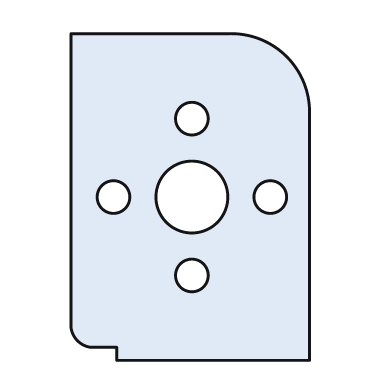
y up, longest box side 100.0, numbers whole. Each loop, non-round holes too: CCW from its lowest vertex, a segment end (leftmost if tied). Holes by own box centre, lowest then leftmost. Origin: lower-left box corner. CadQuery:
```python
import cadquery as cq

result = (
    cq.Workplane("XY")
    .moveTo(14.0, 0.0)
    .lineTo(73.0, 0.0)
    .lineTo(73.0, 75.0)
    .threePointArc((66.0, 93.0), (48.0, 100.0))
    .lineTo(0.0, 100.0)
    .lineTo(0.0, 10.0)
    .threePointArc((2.0, 6.0), (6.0, 4.0))
    .lineTo(14.0, 4.0)
    .close()
    .moveTo(37.0, 26.0)
    .circle(5.0)
    .moveTo(13.0, 50.0)
    .circle(5.0)
    .moveTo(37.0, 50.0)
    .circle(11.0)
    .moveTo(61.0, 50.0)
    .circle(5.0)
    .moveTo(37.0, 74.0)
    .circle(5.0)
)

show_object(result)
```